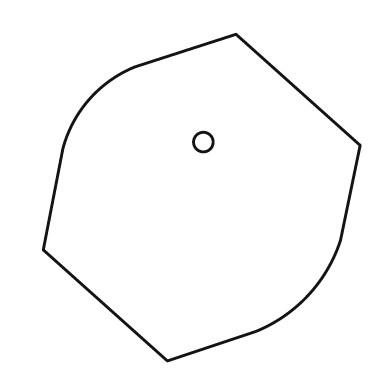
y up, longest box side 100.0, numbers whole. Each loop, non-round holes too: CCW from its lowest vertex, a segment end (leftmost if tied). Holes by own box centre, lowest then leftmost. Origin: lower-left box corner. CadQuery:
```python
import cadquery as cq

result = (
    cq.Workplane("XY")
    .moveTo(38.0, 0.0)
    .lineTo(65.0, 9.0)
    .threePointArc((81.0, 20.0), (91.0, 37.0))
    .lineTo(97.0, 66.0)
    .lineTo(59.0, 100.0)
    .lineTo(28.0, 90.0)
    .threePointArc((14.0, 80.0), (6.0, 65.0))
    .lineTo(0.0, 34.0)
    .close()
    .moveTo(49.0, 67.0)
    .circle(3.0)
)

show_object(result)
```